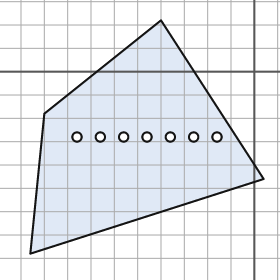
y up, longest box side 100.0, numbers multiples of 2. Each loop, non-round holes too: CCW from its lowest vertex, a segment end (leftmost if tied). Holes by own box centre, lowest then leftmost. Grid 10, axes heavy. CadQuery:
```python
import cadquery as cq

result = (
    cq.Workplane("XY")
    .moveTo(-96.0, -78.0)
    .lineTo(4.0, -46.0)
    .lineTo(-40.0, 22.0)
    .lineTo(-90.0, -18.0)
    .close()
    .moveTo(-76.0, -28.0)
    .circle(2.0)
    .moveTo(-66.0, -28.0)
    .circle(2.0)
    .moveTo(-56.0, -28.0)
    .circle(2.0)
    .moveTo(-46.0, -28.0)
    .circle(2.0)
    .moveTo(-36.0, -28.0)
    .circle(2.0)
    .moveTo(-26.0, -28.0)
    .circle(2.0)
    .moveTo(-16.0, -28.0)
    .circle(2.0)
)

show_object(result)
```